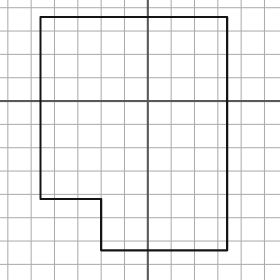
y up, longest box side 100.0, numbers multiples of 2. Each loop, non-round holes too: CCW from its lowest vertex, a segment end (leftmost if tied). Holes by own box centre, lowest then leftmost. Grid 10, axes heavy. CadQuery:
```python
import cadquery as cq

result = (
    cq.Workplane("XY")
    .moveTo(-20.0, -64.0)
    .lineTo(34.0, -64.0)
    .lineTo(34.0, 36.0)
    .lineTo(-46.0, 36.0)
    .lineTo(-46.0, -42.0)
    .lineTo(-20.0, -42.0)
    .close()
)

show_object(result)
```